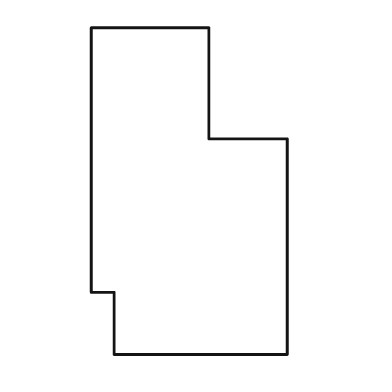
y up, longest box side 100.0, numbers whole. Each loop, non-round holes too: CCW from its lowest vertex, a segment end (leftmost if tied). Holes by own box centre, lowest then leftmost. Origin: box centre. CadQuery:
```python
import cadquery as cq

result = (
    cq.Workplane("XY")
    .moveTo(-23.0, -50.0)
    .lineTo(30.0, -50.0)
    .lineTo(30.0, 16.0)
    .lineTo(6.0, 16.0)
    .lineTo(6.0, 50.0)
    .lineTo(-30.0, 50.0)
    .lineTo(-30.0, -31.0)
    .lineTo(-23.0, -31.0)
    .close()
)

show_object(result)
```